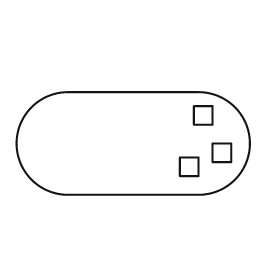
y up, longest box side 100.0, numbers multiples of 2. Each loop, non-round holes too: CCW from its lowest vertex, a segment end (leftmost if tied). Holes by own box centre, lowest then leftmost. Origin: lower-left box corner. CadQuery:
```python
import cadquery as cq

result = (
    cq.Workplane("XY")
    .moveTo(22.0, 0.0)
    .lineTo(78.0, 0.0)
    .threePointArc((100.0, 22.0), (78.0, 44.0))
    .lineTo(22.0, 44.0)
    .threePointArc((0.0, 22.0), (22.0, 0.0))
    .close()
    .moveTo(70.0, 8.0)
    .lineTo(78.0, 8.0)
    .lineTo(78.0, 16.0)
    .lineTo(70.0, 16.0)
    .close()
    .moveTo(84.0, 14.0)
    .lineTo(92.0, 14.0)
    .lineTo(92.0, 22.0)
    .lineTo(84.0, 22.0)
    .close()
    .moveTo(76.0, 30.0)
    .lineTo(84.0, 30.0)
    .lineTo(84.0, 38.0)
    .lineTo(76.0, 38.0)
    .close()
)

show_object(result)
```